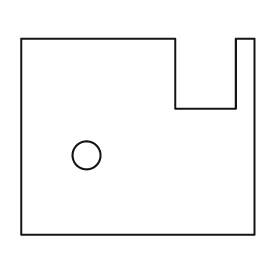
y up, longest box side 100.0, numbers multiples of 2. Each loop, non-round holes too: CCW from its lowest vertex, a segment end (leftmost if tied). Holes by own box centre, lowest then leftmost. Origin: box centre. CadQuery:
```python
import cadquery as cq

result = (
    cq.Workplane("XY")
    .moveTo(-50.0, -42.0)
    .lineTo(50.0, -42.0)
    .lineTo(50.0, 42.0)
    .lineTo(42.0, 42.0)
    .lineTo(42.0, 12.0)
    .lineTo(16.0, 12.0)
    .lineTo(16.0, 42.0)
    .lineTo(-50.0, 42.0)
    .close()
    .moveTo(-22.0, -8.0)
    .circle(6.0)
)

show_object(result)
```